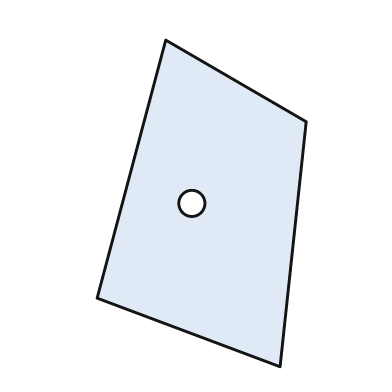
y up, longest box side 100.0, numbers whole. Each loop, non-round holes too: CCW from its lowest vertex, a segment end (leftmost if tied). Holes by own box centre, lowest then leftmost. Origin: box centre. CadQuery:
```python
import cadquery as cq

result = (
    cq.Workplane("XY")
    .moveTo(24.0, -50.0)
    .lineTo(32.0, 25.0)
    .lineTo(-11.0, 50.0)
    .lineTo(-32.0, -29.0)
    .close()
    .moveTo(-3.0, 0.0)
    .circle(4.0)
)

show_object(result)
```